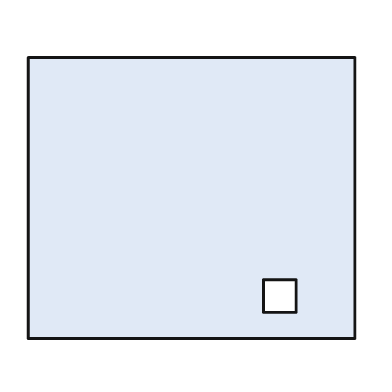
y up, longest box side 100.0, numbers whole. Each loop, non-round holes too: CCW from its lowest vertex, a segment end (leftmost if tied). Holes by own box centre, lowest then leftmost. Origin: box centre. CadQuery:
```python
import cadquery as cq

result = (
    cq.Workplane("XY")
    .moveTo(-50.0, -43.0)
    .lineTo(50.0, -43.0)
    .lineTo(50.0, 43.0)
    .lineTo(-50.0, 43.0)
    .close()
    .moveTo(22.0, -35.0)
    .lineTo(32.0, -35.0)
    .lineTo(32.0, -25.0)
    .lineTo(22.0, -25.0)
    .close()
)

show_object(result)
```